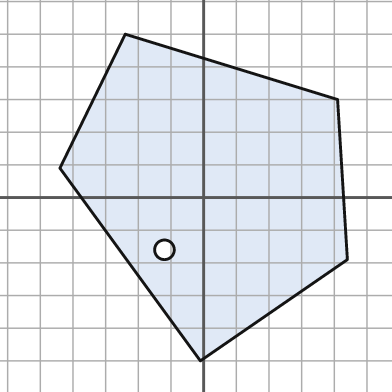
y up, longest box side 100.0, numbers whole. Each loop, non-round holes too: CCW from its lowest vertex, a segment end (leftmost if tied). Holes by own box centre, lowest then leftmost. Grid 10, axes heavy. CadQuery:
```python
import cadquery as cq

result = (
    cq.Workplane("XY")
    .moveTo(-1.0, -50.0)
    .lineTo(44.0, -19.0)
    .lineTo(41.0, 30.0)
    .lineTo(-24.0, 50.0)
    .lineTo(-44.0, 9.0)
    .close()
    .moveTo(-12.0, -16.0)
    .circle(3.0)
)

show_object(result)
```